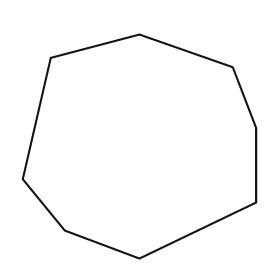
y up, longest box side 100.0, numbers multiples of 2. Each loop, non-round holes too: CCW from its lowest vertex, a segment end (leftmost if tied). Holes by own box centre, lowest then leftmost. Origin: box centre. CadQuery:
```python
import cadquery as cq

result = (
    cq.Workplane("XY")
    .moveTo(0.0, -48.0)
    .lineTo(50.0, -24.0)
    .lineTo(50.0, 8.0)
    .lineTo(40.0, 34.0)
    .lineTo(0.0, 48.0)
    .lineTo(-38.0, 38.0)
    .lineTo(-50.0, -14.0)
    .lineTo(-32.0, -36.0)
    .close()
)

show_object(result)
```